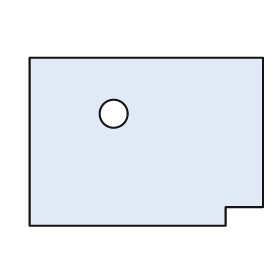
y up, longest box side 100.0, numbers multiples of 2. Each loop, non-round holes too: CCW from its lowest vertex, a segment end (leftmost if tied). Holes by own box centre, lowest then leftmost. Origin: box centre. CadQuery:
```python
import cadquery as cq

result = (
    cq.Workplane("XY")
    .moveTo(-50.0, -36.0)
    .lineTo(34.0, -36.0)
    .lineTo(34.0, -28.0)
    .lineTo(50.0, -28.0)
    .lineTo(50.0, 36.0)
    .lineTo(-50.0, 36.0)
    .close()
    .moveTo(-14.0, 12.0)
    .circle(6.0)
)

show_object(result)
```